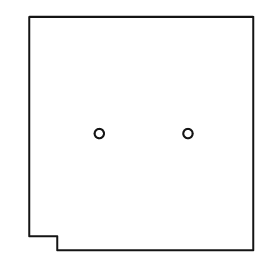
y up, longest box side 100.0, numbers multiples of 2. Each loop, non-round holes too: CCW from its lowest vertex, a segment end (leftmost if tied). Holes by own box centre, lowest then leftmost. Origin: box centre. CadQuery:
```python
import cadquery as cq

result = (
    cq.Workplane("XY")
    .moveTo(-36.0, -50.0)
    .lineTo(48.0, -50.0)
    .lineTo(48.0, 50.0)
    .lineTo(-48.0, 50.0)
    .lineTo(-48.0, -44.0)
    .lineTo(-36.0, -44.0)
    .close()
    .moveTo(-18.0, 0.0)
    .circle(2.0)
    .moveTo(20.0, 0.0)
    .circle(2.0)
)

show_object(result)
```